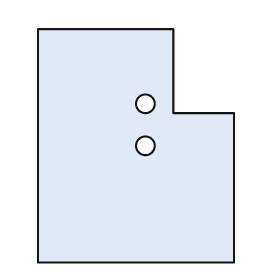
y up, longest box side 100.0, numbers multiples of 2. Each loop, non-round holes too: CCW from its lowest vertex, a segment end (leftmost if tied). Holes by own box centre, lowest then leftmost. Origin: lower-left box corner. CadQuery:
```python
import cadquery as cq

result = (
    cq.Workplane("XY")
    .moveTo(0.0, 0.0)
    .lineTo(84.0, 0.0)
    .lineTo(84.0, 64.0)
    .lineTo(58.0, 64.0)
    .lineTo(58.0, 100.0)
    .lineTo(0.0, 100.0)
    .close()
    .moveTo(46.0, 50.0)
    .circle(4.0)
    .moveTo(46.0, 68.0)
    .circle(4.0)
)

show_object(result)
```